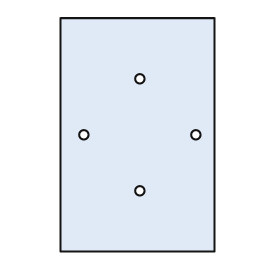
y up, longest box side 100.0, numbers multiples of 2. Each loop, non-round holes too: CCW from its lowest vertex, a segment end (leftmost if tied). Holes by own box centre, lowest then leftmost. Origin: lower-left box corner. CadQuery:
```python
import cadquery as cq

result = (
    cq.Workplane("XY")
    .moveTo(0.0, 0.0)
    .lineTo(66.0, 0.0)
    .lineTo(66.0, 100.0)
    .lineTo(0.0, 100.0)
    .close()
    .moveTo(34.0, 26.0)
    .circle(2.0)
    .moveTo(10.0, 50.0)
    .circle(2.0)
    .moveTo(58.0, 50.0)
    .circle(2.0)
    .moveTo(34.0, 74.0)
    .circle(2.0)
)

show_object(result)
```